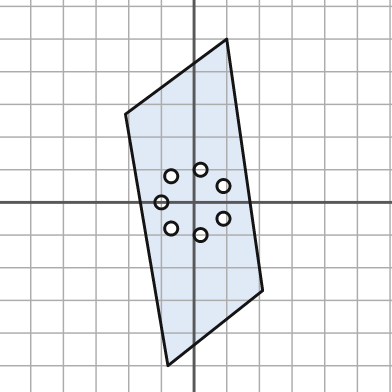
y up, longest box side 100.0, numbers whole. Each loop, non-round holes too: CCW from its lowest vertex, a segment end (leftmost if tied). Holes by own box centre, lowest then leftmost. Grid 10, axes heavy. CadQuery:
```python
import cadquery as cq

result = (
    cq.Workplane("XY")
    .moveTo(-8.0, -50.0)
    .lineTo(21.0, -27.0)
    .lineTo(10.0, 50.0)
    .lineTo(-21.0, 27.0)
    .close()
    .moveTo(2.0, -10.0)
    .circle(2.0)
    .moveTo(-7.0, -8.0)
    .circle(2.0)
    .moveTo(9.0, -5.0)
    .circle(2.0)
    .moveTo(-10.0, 0.0)
    .circle(2.0)
    .moveTo(9.0, 5.0)
    .circle(2.0)
    .moveTo(-7.0, 8.0)
    .circle(2.0)
    .moveTo(2.0, 10.0)
    .circle(2.0)
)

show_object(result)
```